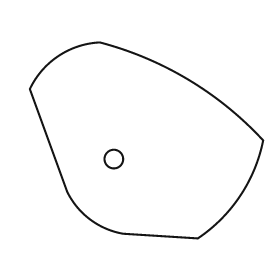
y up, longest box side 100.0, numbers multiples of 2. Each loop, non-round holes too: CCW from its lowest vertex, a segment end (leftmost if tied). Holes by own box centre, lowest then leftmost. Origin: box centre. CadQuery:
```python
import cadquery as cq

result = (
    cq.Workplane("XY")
    .moveTo(22.0, -42.0)
    .threePointArc((40.0, -24.0), (50.0, 0.0))
    .threePointArc((18.0, 26.0), (-20.0, 42.0))
    .threePointArc((-38.0, 36.0), (-50.0, 22.0))
    .lineTo(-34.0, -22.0)
    .threePointArc((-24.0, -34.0), (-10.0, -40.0))
    .close()
    .moveTo(-14.0, -8.0)
    .circle(4.0)
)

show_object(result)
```